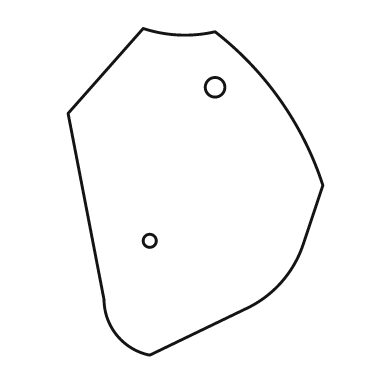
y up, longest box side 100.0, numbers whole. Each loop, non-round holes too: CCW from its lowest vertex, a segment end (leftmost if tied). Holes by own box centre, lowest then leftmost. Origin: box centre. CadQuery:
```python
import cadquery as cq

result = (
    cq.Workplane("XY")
    .moveTo(-14.0, -50.0)
    .lineTo(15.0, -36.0)
    .threePointArc((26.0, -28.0), (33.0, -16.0))
    .lineTo(39.0, 2.0)
    .threePointArc((26.0, 28.0), (6.0, 49.0))
    .threePointArc((-5.0, 48.0), (-16.0, 50.0))
    .lineTo(-39.0, 24.0)
    .lineTo(-28.0, -33.0)
    .threePointArc((-24.0, -44.0), (-14.0, -50.0))
    .close()
    .moveTo(-14.0, -15.0)
    .circle(2.0)
    .moveTo(6.0, 32.0)
    .circle(3.0)
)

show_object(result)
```